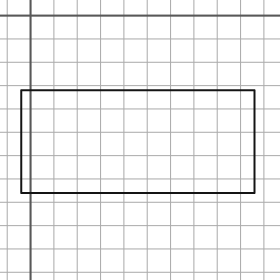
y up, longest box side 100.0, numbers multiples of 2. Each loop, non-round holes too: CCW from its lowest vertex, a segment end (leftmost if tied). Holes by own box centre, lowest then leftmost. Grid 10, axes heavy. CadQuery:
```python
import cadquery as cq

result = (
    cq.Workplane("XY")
    .moveTo(-4.0, -76.0)
    .lineTo(96.0, -76.0)
    .lineTo(96.0, -32.0)
    .lineTo(-4.0, -32.0)
    .close()
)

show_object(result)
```